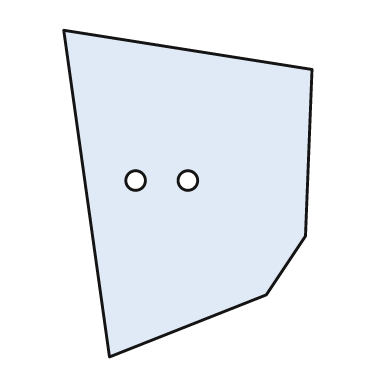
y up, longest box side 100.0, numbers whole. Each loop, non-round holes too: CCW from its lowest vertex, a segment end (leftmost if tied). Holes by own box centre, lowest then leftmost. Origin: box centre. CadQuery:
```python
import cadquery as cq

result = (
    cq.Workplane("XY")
    .moveTo(-24.0, -50.0)
    .lineTo(24.0, -31.0)
    .lineTo(36.0, -13.0)
    .lineTo(38.0, 38.0)
    .lineTo(-38.0, 50.0)
    .close()
    .moveTo(-16.0, 4.0)
    .circle(3.0)
    .moveTo(0.0, 4.0)
    .circle(3.0)
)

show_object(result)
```